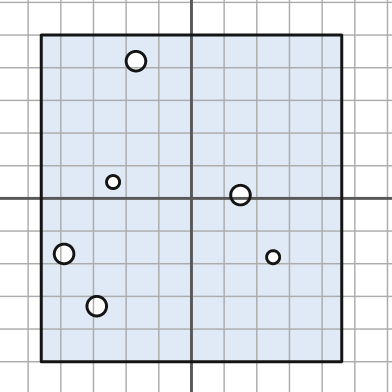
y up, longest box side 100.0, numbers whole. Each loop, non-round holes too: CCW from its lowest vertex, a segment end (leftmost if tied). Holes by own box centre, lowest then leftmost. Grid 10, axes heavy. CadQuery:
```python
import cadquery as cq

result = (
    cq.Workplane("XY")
    .moveTo(-46.0, -50.0)
    .lineTo(46.0, -50.0)
    .lineTo(46.0, 50.0)
    .lineTo(-46.0, 50.0)
    .close()
    .moveTo(-29.0, -33.0)
    .circle(3.0)
    .moveTo(25.0, -18.0)
    .circle(2.0)
    .moveTo(-39.0, -17.0)
    .circle(3.0)
    .moveTo(15.0, 1.0)
    .circle(3.0)
    .moveTo(-24.0, 5.0)
    .circle(2.0)
    .moveTo(-17.0, 42.0)
    .circle(3.0)
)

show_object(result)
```